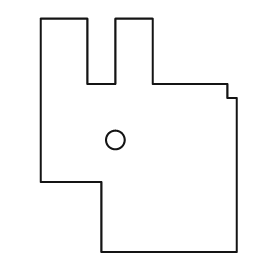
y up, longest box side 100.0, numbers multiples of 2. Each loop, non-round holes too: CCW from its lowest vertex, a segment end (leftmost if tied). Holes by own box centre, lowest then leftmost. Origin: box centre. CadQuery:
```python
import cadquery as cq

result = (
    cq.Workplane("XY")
    .moveTo(-16.0, -50.0)
    .lineTo(42.0, -50.0)
    .lineTo(42.0, 16.0)
    .lineTo(38.0, 16.0)
    .lineTo(38.0, 22.0)
    .lineTo(6.0, 22.0)
    .lineTo(6.0, 50.0)
    .lineTo(-10.0, 50.0)
    .lineTo(-10.0, 22.0)
    .lineTo(-22.0, 22.0)
    .lineTo(-22.0, 50.0)
    .lineTo(-42.0, 50.0)
    .lineTo(-42.0, -20.0)
    .lineTo(-16.0, -20.0)
    .close()
    .moveTo(-10.0, -2.0)
    .circle(4.0)
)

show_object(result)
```